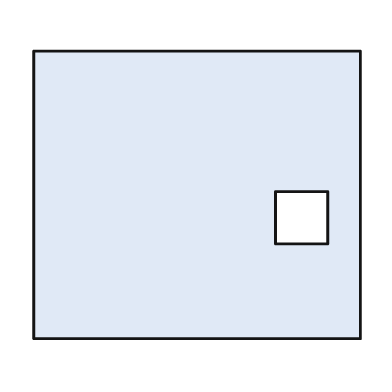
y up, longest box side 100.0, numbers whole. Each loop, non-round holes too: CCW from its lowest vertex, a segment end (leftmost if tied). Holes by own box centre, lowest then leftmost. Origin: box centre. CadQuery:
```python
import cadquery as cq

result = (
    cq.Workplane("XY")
    .moveTo(-50.0, -44.0)
    .lineTo(50.0, -44.0)
    .lineTo(50.0, 44.0)
    .lineTo(-50.0, 44.0)
    .close()
    .moveTo(24.0, -15.0)
    .lineTo(40.0, -15.0)
    .lineTo(40.0, 1.0)
    .lineTo(24.0, 1.0)
    .close()
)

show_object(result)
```